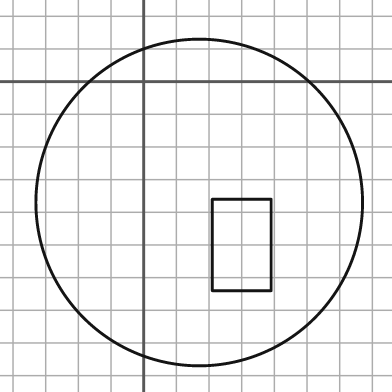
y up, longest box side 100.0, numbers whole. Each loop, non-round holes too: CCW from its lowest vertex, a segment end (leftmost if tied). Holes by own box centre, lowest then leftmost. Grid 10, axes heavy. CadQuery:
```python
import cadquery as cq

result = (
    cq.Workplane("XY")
    .moveTo(17.0, -37.0)
    .circle(50.0)
    .moveTo(21.0, -64.0)
    .lineTo(39.0, -64.0)
    .lineTo(39.0, -36.0)
    .lineTo(21.0, -36.0)
    .close()
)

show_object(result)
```